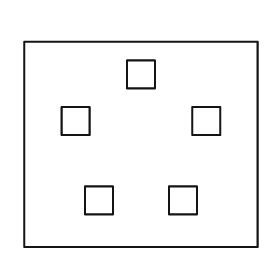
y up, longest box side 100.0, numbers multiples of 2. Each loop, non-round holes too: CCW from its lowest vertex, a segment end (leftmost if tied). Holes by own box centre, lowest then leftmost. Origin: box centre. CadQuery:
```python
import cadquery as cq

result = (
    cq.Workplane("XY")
    .moveTo(-50.0, -44.0)
    .lineTo(50.0, -44.0)
    .lineTo(50.0, 44.0)
    .lineTo(-50.0, 44.0)
    .close()
    .moveTo(-24.0, -30.0)
    .lineTo(-12.0, -30.0)
    .lineTo(-12.0, -18.0)
    .lineTo(-24.0, -18.0)
    .close()
    .moveTo(12.0, -30.0)
    .lineTo(24.0, -30.0)
    .lineTo(24.0, -18.0)
    .lineTo(12.0, -18.0)
    .close()
    .moveTo(-34.0, 4.0)
    .lineTo(-22.0, 4.0)
    .lineTo(-22.0, 16.0)
    .lineTo(-34.0, 16.0)
    .close()
    .moveTo(22.0, 4.0)
    .lineTo(34.0, 4.0)
    .lineTo(34.0, 16.0)
    .lineTo(22.0, 16.0)
    .close()
    .moveTo(-6.0, 24.0)
    .lineTo(6.0, 24.0)
    .lineTo(6.0, 36.0)
    .lineTo(-6.0, 36.0)
    .close()
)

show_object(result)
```